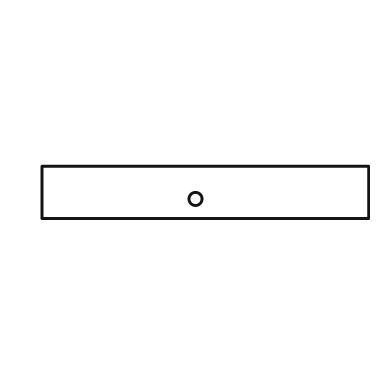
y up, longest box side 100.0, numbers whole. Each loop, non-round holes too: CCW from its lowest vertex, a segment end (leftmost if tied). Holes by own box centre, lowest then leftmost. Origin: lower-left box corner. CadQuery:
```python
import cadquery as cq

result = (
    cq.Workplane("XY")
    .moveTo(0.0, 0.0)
    .lineTo(100.0, 0.0)
    .lineTo(100.0, 16.0)
    .lineTo(0.0, 16.0)
    .close()
    .moveTo(47.0, 6.0)
    .circle(2.0)
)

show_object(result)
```